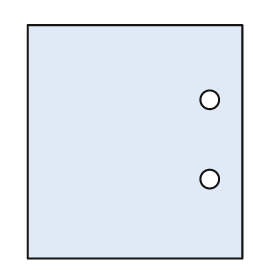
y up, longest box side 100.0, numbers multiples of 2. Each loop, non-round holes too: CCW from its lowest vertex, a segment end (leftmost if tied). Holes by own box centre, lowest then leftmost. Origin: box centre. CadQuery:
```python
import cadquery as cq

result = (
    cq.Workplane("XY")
    .moveTo(-46.0, -50.0)
    .lineTo(46.0, -50.0)
    .lineTo(46.0, 50.0)
    .lineTo(-46.0, 50.0)
    .close()
    .moveTo(32.0, -16.0)
    .circle(4.0)
    .moveTo(32.0, 18.0)
    .circle(4.0)
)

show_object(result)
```